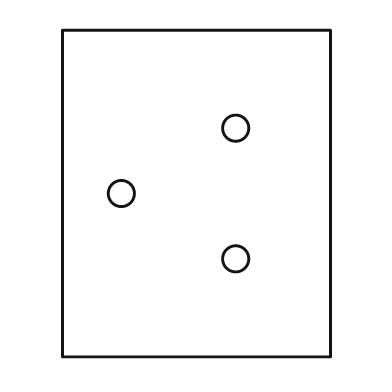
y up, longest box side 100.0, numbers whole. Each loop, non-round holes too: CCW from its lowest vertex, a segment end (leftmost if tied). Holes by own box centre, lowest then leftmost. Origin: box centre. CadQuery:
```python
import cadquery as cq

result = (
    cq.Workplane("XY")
    .moveTo(-41.0, -50.0)
    .lineTo(41.0, -50.0)
    .lineTo(41.0, 50.0)
    .lineTo(-41.0, 50.0)
    .close()
    .moveTo(12.0, -20.0)
    .circle(4.0)
    .moveTo(-23.0, 0.0)
    .circle(4.0)
    .moveTo(12.0, 20.0)
    .circle(4.0)
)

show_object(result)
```